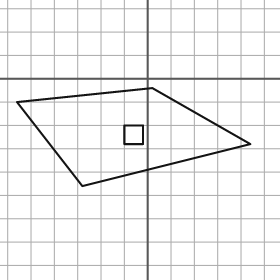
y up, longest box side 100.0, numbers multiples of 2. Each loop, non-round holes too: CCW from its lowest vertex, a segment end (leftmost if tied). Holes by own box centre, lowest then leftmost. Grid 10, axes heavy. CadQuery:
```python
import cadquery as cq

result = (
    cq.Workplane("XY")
    .moveTo(-28.0, -46.0)
    .lineTo(44.0, -28.0)
    .lineTo(2.0, -4.0)
    .lineTo(-56.0, -10.0)
    .close()
    .moveTo(-10.0, -28.0)
    .lineTo(-2.0, -28.0)
    .lineTo(-2.0, -20.0)
    .lineTo(-10.0, -20.0)
    .close()
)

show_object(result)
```